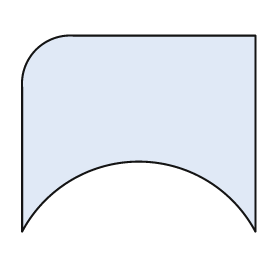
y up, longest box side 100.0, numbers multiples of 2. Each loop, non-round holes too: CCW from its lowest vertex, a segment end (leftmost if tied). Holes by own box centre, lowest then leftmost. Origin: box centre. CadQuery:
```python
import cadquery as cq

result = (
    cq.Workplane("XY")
    .moveTo(-50.0, -42.0)
    .threePointArc((0.0, -12.0), (50.0, -42.0))
    .lineTo(50.0, 42.0)
    .lineTo(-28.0, 42.0)
    .threePointArc((-44.0, 36.0), (-50.0, 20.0))
    .close()
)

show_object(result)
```